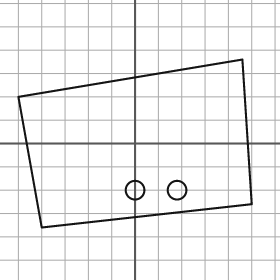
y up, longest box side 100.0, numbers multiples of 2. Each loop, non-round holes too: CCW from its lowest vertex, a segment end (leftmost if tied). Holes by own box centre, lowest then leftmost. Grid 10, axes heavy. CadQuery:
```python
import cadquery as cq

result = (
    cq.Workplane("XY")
    .moveTo(-40.0, -36.0)
    .lineTo(50.0, -26.0)
    .lineTo(46.0, 36.0)
    .lineTo(-50.0, 20.0)
    .close()
    .moveTo(0.0, -20.0)
    .circle(4.0)
    .moveTo(18.0, -20.0)
    .circle(4.0)
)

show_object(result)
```